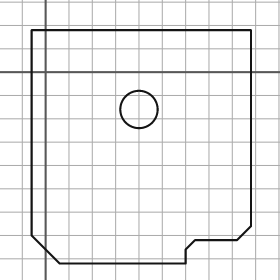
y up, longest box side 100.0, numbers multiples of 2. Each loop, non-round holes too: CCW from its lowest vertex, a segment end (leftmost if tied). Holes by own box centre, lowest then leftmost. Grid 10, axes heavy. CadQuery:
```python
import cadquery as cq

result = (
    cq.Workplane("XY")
    .moveTo(6.0, -82.0)
    .lineTo(60.0, -82.0)
    .lineTo(60.0, -76.0)
    .lineTo(64.0, -72.0)
    .lineTo(82.0, -72.0)
    .lineTo(88.0, -66.0)
    .lineTo(88.0, 18.0)
    .lineTo(-6.0, 18.0)
    .lineTo(-6.0, -70.0)
    .close()
    .moveTo(40.0, -16.0)
    .circle(8.0)
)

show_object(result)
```